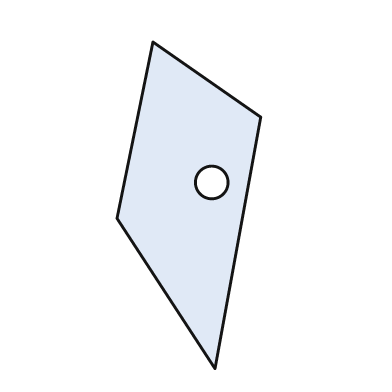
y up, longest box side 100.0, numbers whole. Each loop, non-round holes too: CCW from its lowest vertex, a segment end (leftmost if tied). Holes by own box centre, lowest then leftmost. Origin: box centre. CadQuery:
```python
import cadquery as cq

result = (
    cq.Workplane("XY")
    .moveTo(8.0, -50.0)
    .lineTo(22.0, 27.0)
    .lineTo(-11.0, 50.0)
    .lineTo(-22.0, -4.0)
    .close()
    .moveTo(7.0, 7.0)
    .circle(5.0)
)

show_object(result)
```